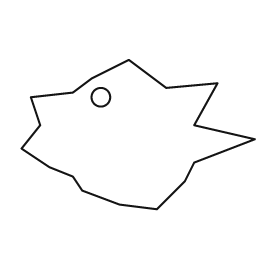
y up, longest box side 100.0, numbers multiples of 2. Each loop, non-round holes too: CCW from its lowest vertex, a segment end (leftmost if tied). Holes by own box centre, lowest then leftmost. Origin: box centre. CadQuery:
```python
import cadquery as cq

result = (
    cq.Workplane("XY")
    .moveTo(8.0, -32.0)
    .lineTo(20.0, -20.0)
    .lineTo(24.0, -12.0)
    .lineTo(50.0, -2.0)
    .lineTo(24.0, 4.0)
    .lineTo(34.0, 22.0)
    .lineTo(12.0, 20.0)
    .lineTo(-4.0, 32.0)
    .lineTo(-20.0, 24.0)
    .lineTo(-28.0, 18.0)
    .lineTo(-46.0, 16.0)
    .lineTo(-42.0, 4.0)
    .lineTo(-50.0, -6.0)
    .lineTo(-38.0, -14.0)
    .lineTo(-28.0, -18.0)
    .lineTo(-24.0, -24.0)
    .lineTo(-8.0, -30.0)
    .close()
    .moveTo(-16.0, 16.0)
    .circle(4.0)
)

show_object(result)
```